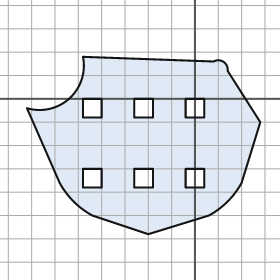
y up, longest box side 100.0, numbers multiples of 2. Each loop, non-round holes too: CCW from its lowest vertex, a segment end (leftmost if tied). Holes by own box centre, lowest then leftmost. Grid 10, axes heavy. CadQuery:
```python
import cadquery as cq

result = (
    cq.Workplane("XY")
    .moveTo(-20.0, -58.0)
    .lineTo(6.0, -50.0)
    .threePointArc((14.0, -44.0), (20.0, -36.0))
    .lineTo(28.0, -10.0)
    .lineTo(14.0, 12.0)
    .threePointArc((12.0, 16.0), (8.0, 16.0))
    .lineTo(-48.0, 18.0)
    .threePointArc((-54.0, 0.0), (-72.0, -4.0))
    .lineTo(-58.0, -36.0)
    .threePointArc((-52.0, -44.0), (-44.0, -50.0))
    .close()
    .moveTo(-48.0, -38.0)
    .lineTo(-40.0, -38.0)
    .lineTo(-40.0, -30.0)
    .lineTo(-48.0, -30.0)
    .close()
    .moveTo(-26.0, -38.0)
    .lineTo(-18.0, -38.0)
    .lineTo(-18.0, -30.0)
    .lineTo(-26.0, -30.0)
    .close()
    .moveTo(-4.0, -38.0)
    .lineTo(4.0, -38.0)
    .lineTo(4.0, -30.0)
    .lineTo(-4.0, -30.0)
    .close()
    .moveTo(-48.0, -8.0)
    .lineTo(-40.0, -8.0)
    .lineTo(-40.0, 0.0)
    .lineTo(-48.0, 0.0)
    .close()
    .moveTo(-26.0, -8.0)
    .lineTo(-18.0, -8.0)
    .lineTo(-18.0, 0.0)
    .lineTo(-26.0, 0.0)
    .close()
    .moveTo(-4.0, -8.0)
    .lineTo(4.0, -8.0)
    .lineTo(4.0, 0.0)
    .lineTo(-4.0, 0.0)
    .close()
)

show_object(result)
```